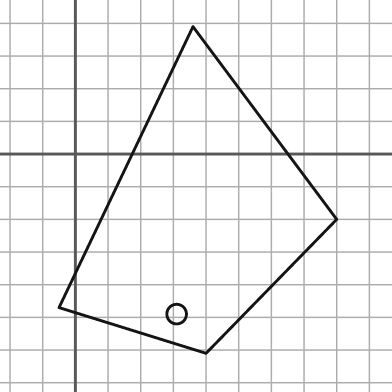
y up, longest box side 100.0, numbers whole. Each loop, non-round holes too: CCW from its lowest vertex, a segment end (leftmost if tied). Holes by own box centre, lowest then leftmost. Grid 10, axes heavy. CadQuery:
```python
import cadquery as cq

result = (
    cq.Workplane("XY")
    .moveTo(40.0, -61.0)
    .lineTo(80.0, -20.0)
    .lineTo(36.0, 39.0)
    .lineTo(-5.0, -47.0)
    .close()
    .moveTo(31.0, -49.0)
    .circle(3.0)
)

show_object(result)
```